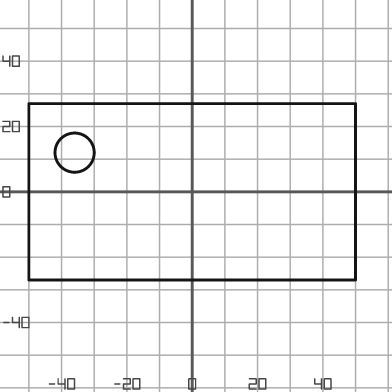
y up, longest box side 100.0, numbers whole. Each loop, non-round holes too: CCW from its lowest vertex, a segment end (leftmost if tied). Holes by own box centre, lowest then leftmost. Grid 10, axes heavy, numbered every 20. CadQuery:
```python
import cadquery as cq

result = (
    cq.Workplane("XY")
    .moveTo(-50.0, -27.0)
    .lineTo(50.0, -27.0)
    .lineTo(50.0, 27.0)
    .lineTo(-50.0, 27.0)
    .close()
    .moveTo(-36.0, 12.0)
    .circle(6.0)
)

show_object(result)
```